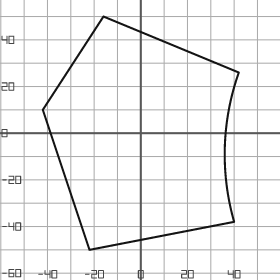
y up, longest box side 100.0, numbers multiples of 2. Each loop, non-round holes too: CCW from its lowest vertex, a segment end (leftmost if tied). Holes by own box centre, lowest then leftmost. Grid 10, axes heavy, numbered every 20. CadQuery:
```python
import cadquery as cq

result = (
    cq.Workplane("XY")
    .moveTo(-22.0, -50.0)
    .lineTo(40.0, -38.0)
    .threePointArc((36.0, -6.0), (42.0, 26.0))
    .lineTo(-16.0, 50.0)
    .lineTo(-42.0, 10.0)
    .close()
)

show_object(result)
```